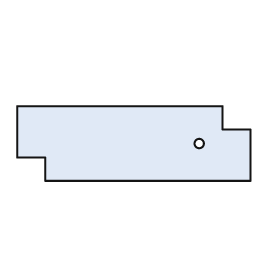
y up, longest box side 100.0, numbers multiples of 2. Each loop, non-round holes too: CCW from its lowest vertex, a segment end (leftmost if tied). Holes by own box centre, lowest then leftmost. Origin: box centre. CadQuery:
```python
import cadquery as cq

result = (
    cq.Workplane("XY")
    .moveTo(-38.0, -16.0)
    .lineTo(50.0, -16.0)
    .lineTo(50.0, 6.0)
    .lineTo(38.0, 6.0)
    .lineTo(38.0, 16.0)
    .lineTo(-50.0, 16.0)
    .lineTo(-50.0, -6.0)
    .lineTo(-38.0, -6.0)
    .close()
    .moveTo(28.0, 0.0)
    .circle(2.0)
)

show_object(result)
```